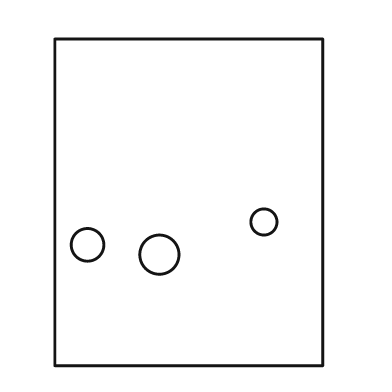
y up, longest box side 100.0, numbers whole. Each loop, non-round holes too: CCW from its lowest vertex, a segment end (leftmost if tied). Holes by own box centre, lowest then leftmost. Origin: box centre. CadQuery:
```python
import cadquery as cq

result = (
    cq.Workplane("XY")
    .moveTo(-41.0, -50.0)
    .lineTo(41.0, -50.0)
    .lineTo(41.0, 50.0)
    .lineTo(-41.0, 50.0)
    .close()
    .moveTo(-9.0, -16.0)
    .circle(6.0)
    .moveTo(-31.0, -13.0)
    .circle(5.0)
    .moveTo(23.0, -6.0)
    .circle(4.0)
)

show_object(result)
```